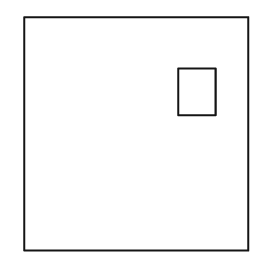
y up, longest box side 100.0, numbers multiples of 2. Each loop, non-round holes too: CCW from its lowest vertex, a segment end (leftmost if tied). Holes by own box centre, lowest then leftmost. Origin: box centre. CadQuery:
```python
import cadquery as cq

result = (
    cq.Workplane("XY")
    .moveTo(-48.0, -50.0)
    .lineTo(48.0, -50.0)
    .lineTo(48.0, 50.0)
    .lineTo(-48.0, 50.0)
    .close()
    .moveTo(18.0, 8.0)
    .lineTo(34.0, 8.0)
    .lineTo(34.0, 28.0)
    .lineTo(18.0, 28.0)
    .close()
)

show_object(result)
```